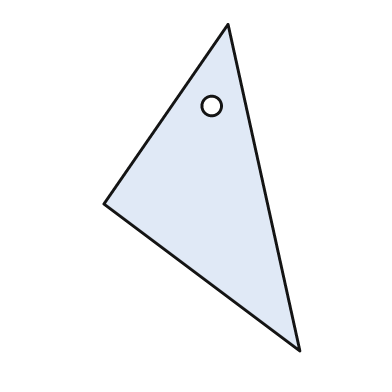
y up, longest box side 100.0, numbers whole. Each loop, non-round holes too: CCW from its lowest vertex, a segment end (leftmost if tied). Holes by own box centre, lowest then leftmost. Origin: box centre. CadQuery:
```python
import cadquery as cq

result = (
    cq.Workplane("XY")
    .moveTo(30.0, -50.0)
    .lineTo(8.0, 50.0)
    .lineTo(-30.0, -5.0)
    .close()
    .moveTo(3.0, 25.0)
    .circle(3.0)
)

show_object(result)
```